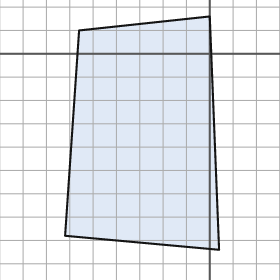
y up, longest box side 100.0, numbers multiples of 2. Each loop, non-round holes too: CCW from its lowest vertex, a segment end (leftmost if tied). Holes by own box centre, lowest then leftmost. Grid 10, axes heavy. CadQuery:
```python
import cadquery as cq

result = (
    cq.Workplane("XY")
    .moveTo(4.0, -84.0)
    .lineTo(0.0, 16.0)
    .lineTo(-56.0, 10.0)
    .lineTo(-62.0, -78.0)
    .close()
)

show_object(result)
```